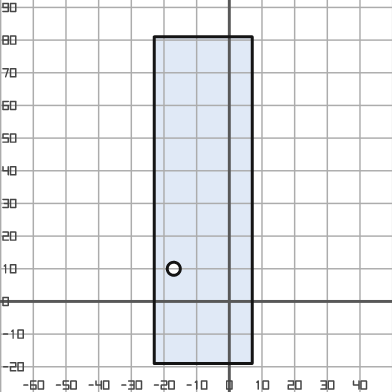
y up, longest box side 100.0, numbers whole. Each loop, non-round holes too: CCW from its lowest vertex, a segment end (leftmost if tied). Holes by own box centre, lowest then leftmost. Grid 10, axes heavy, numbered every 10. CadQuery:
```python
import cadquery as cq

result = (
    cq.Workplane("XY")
    .moveTo(-23.0, -19.0)
    .lineTo(7.0, -19.0)
    .lineTo(7.0, 81.0)
    .lineTo(-23.0, 81.0)
    .close()
    .moveTo(-17.0, 10.0)
    .circle(2.0)
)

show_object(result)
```